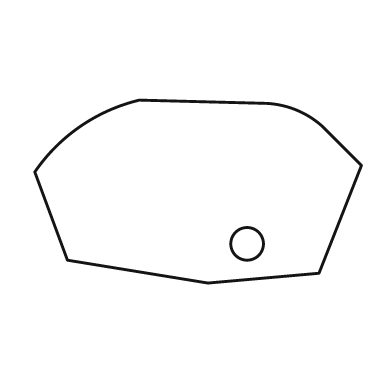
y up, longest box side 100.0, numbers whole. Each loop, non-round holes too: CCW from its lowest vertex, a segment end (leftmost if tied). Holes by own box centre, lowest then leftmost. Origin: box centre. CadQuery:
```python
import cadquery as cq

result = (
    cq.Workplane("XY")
    .moveTo(3.0, -28.0)
    .lineTo(37.0, -25.0)
    .lineTo(50.0, 8.0)
    .lineTo(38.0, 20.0)
    .threePointArc((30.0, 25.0), (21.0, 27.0))
    .lineTo(-18.0, 28.0)
    .threePointArc((-36.0, 20.0), (-50.0, 6.0))
    .lineTo(-40.0, -21.0)
    .close()
    .moveTo(15.0, -16.0)
    .circle(5.0)
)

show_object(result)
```